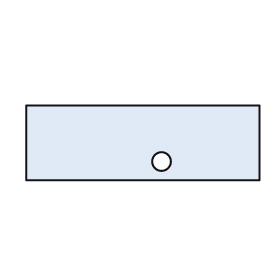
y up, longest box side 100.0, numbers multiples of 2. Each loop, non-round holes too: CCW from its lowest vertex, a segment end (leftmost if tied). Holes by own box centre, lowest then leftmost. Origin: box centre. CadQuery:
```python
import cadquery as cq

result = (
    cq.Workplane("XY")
    .moveTo(-50.0, -16.0)
    .lineTo(50.0, -16.0)
    .lineTo(50.0, 16.0)
    .lineTo(-50.0, 16.0)
    .close()
    .moveTo(8.0, -8.0)
    .circle(4.0)
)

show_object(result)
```